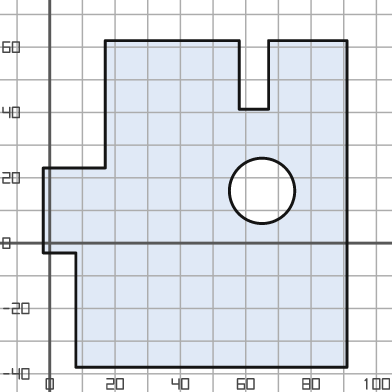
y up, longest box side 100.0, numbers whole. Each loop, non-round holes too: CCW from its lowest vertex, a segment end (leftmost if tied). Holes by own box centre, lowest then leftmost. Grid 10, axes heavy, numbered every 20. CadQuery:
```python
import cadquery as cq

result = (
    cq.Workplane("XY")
    .moveTo(8.0, -38.0)
    .lineTo(91.0, -38.0)
    .lineTo(91.0, 62.0)
    .lineTo(67.0, 62.0)
    .lineTo(67.0, 41.0)
    .lineTo(58.0, 41.0)
    .lineTo(58.0, 62.0)
    .lineTo(17.0, 62.0)
    .lineTo(17.0, 23.0)
    .lineTo(-2.0, 23.0)
    .lineTo(-2.0, -3.0)
    .lineTo(8.0, -3.0)
    .close()
    .moveTo(65.0, 16.0)
    .circle(10.0)
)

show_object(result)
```